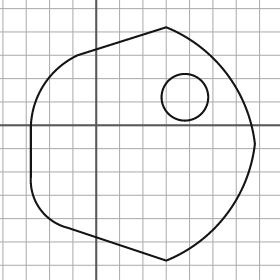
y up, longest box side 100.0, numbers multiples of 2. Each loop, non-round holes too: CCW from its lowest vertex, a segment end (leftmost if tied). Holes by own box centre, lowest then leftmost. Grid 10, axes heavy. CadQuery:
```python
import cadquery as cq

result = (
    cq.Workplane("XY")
    .moveTo(30.0, -58.0)
    .threePointArc((56.0, -38.0), (68.0, -8.0))
    .threePointArc((56.0, 22.0), (30.0, 42.0))
    .lineTo(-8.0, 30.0)
    .threePointArc((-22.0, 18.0), (-28.0, 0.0))
    .lineTo(-28.0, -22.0)
    .threePointArc((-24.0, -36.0), (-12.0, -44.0))
    .close()
    .moveTo(38.0, 12.0)
    .circle(10.0)
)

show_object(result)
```